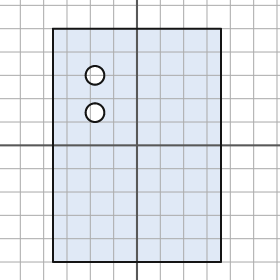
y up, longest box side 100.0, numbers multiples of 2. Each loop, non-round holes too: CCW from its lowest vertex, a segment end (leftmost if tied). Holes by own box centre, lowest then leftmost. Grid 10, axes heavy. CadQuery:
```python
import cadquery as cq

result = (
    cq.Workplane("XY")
    .moveTo(-36.0, -50.0)
    .lineTo(36.0, -50.0)
    .lineTo(36.0, 50.0)
    .lineTo(-36.0, 50.0)
    .close()
    .moveTo(-18.0, 14.0)
    .circle(4.0)
    .moveTo(-18.0, 30.0)
    .circle(4.0)
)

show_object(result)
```